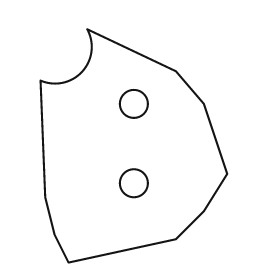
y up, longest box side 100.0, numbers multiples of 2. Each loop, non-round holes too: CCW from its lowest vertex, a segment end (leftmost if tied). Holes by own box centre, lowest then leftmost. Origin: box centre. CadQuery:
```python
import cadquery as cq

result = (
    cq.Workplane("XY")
    .moveTo(-28.0, -50.0)
    .lineTo(18.0, -40.0)
    .lineTo(30.0, -28.0)
    .lineTo(40.0, -12.0)
    .lineTo(30.0, 18.0)
    .lineTo(18.0, 32.0)
    .lineTo(-20.0, 50.0)
    .threePointArc((-22.0, 32.0), (-40.0, 28.0))
    .lineTo(-38.0, -22.0)
    .lineTo(-34.0, -38.0)
    .close()
    .moveTo(0.0, -16.0)
    .circle(6.0)
    .moveTo(0.0, 18.0)
    .circle(6.0)
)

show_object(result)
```